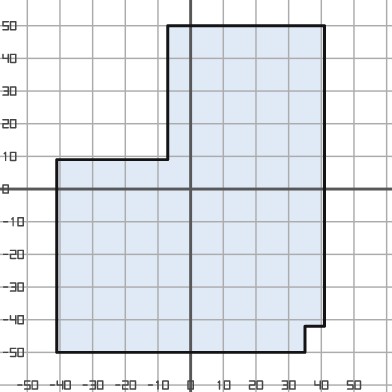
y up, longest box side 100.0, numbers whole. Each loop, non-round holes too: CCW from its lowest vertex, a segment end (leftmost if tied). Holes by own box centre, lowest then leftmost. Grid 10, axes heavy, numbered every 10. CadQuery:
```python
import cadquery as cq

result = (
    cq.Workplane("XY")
    .moveTo(-41.0, -50.0)
    .lineTo(35.0, -50.0)
    .lineTo(35.0, -42.0)
    .lineTo(41.0, -42.0)
    .lineTo(41.0, 50.0)
    .lineTo(-7.0, 50.0)
    .lineTo(-7.0, 9.0)
    .lineTo(-41.0, 9.0)
    .close()
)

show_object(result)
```